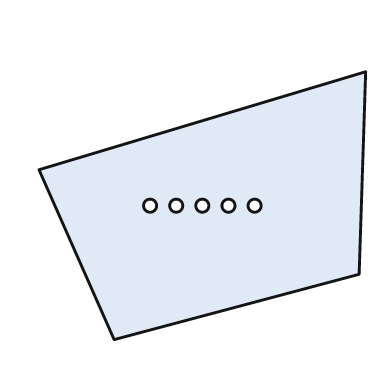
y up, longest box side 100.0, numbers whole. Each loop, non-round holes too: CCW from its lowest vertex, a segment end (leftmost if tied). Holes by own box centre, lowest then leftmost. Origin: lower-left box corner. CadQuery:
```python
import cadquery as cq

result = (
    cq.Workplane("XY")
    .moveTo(23.0, 0.0)
    .lineTo(98.0, 20.0)
    .lineTo(100.0, 82.0)
    .lineTo(0.0, 52.0)
    .close()
    .moveTo(34.0, 41.0)
    .circle(2.0)
    .moveTo(42.0, 41.0)
    .circle(2.0)
    .moveTo(50.0, 41.0)
    .circle(2.0)
    .moveTo(58.0, 41.0)
    .circle(2.0)
    .moveTo(66.0, 41.0)
    .circle(2.0)
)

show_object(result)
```